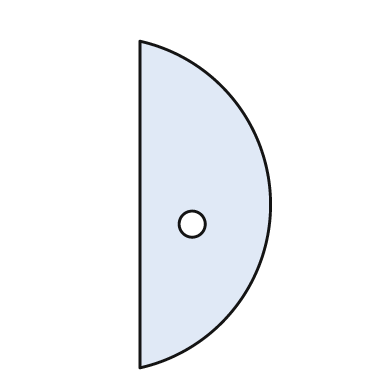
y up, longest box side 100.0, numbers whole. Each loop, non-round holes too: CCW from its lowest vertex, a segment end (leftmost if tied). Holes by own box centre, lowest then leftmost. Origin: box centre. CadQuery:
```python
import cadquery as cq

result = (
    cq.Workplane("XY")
    .moveTo(-20.0, -50.0)
    .threePointArc((20.0, 0.0), (-20.0, 50.0))
    .close()
    .moveTo(-4.0, -6.0)
    .circle(4.0)
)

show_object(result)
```